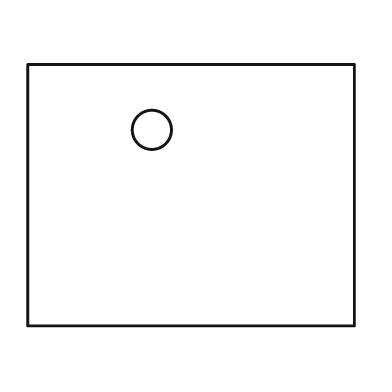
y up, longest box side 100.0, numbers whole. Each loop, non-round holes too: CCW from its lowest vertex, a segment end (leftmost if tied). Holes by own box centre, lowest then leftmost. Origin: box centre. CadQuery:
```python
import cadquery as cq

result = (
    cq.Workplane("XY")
    .moveTo(-50.0, -40.0)
    .lineTo(50.0, -40.0)
    .lineTo(50.0, 40.0)
    .lineTo(-50.0, 40.0)
    .close()
    .moveTo(-12.0, 20.0)
    .circle(6.0)
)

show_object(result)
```